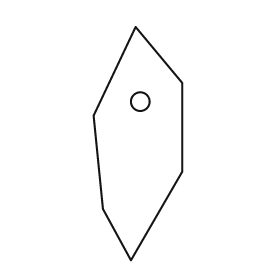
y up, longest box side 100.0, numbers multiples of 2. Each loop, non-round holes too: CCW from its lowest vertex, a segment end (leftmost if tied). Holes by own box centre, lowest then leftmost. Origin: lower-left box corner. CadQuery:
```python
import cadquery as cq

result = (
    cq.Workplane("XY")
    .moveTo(16.0, 0.0)
    .lineTo(38.0, 38.0)
    .lineTo(38.0, 76.0)
    .lineTo(18.0, 100.0)
    .lineTo(0.0, 62.0)
    .lineTo(4.0, 22.0)
    .close()
    .moveTo(20.0, 68.0)
    .circle(4.0)
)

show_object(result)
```